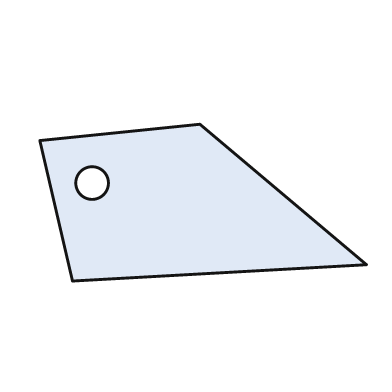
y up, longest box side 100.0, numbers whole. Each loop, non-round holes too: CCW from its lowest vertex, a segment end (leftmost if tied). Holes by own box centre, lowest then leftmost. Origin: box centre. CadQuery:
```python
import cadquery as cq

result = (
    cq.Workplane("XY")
    .moveTo(-40.0, -24.0)
    .lineTo(50.0, -19.0)
    .lineTo(-1.0, 24.0)
    .lineTo(-50.0, 19.0)
    .close()
    .moveTo(-34.0, 6.0)
    .circle(5.0)
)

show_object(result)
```